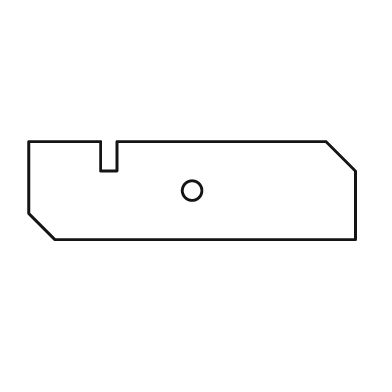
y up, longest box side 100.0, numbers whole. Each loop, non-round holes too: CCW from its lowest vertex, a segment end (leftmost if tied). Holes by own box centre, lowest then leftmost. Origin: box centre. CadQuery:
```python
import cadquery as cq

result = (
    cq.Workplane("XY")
    .moveTo(-42.0, -15.0)
    .lineTo(50.0, -15.0)
    .lineTo(50.0, 6.0)
    .lineTo(41.0, 15.0)
    .lineTo(-23.0, 15.0)
    .lineTo(-23.0, 6.0)
    .lineTo(-28.0, 6.0)
    .lineTo(-28.0, 15.0)
    .lineTo(-50.0, 15.0)
    .lineTo(-50.0, -7.0)
    .close()
    .moveTo(0.0, 0.0)
    .circle(3.0)
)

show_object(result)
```